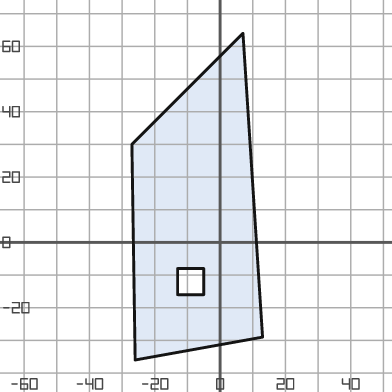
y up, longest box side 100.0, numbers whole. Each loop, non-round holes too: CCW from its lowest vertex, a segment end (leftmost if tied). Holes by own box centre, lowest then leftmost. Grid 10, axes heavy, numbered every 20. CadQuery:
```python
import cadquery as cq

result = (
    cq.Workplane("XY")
    .moveTo(-26.0, -36.0)
    .lineTo(13.0, -29.0)
    .lineTo(7.0, 64.0)
    .lineTo(-27.0, 30.0)
    .close()
    .moveTo(-13.0, -16.0)
    .lineTo(-5.0, -16.0)
    .lineTo(-5.0, -8.0)
    .lineTo(-13.0, -8.0)
    .close()
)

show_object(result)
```